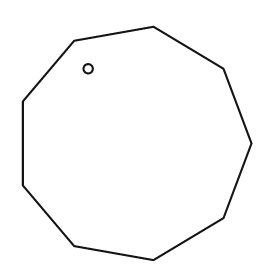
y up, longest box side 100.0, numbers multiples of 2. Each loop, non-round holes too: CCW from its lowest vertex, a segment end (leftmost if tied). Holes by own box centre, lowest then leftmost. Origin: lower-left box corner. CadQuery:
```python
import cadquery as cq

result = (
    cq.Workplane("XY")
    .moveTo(56.0, 0.0)
    .lineTo(86.0, 18.0)
    .lineTo(98.0, 50.0)
    .lineTo(86.0, 82.0)
    .lineTo(56.0, 100.0)
    .lineTo(22.0, 94.0)
    .lineTo(0.0, 68.0)
    .lineTo(0.0, 32.0)
    .lineTo(22.0, 6.0)
    .close()
    .moveTo(28.0, 82.0)
    .circle(2.0)
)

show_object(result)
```